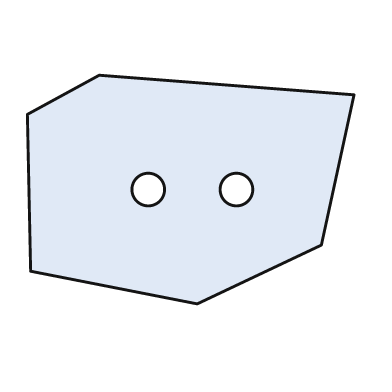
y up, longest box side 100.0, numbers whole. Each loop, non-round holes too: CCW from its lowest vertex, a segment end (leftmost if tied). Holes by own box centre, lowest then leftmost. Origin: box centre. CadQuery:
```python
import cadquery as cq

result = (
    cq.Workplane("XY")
    .moveTo(2.0, -35.0)
    .lineTo(40.0, -17.0)
    .lineTo(50.0, 29.0)
    .lineTo(-28.0, 35.0)
    .lineTo(-50.0, 23.0)
    .lineTo(-49.0, -25.0)
    .close()
    .moveTo(-13.0, 0.0)
    .circle(5.0)
    .moveTo(14.0, 0.0)
    .circle(5.0)
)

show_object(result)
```